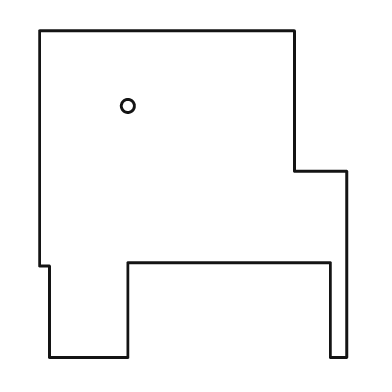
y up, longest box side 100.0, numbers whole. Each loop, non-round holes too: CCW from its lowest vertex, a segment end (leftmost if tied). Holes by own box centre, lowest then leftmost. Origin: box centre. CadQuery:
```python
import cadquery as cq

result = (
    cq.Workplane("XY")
    .moveTo(-44.0, -50.0)
    .lineTo(-20.0, -50.0)
    .lineTo(-20.0, -21.0)
    .lineTo(42.0, -21.0)
    .lineTo(42.0, -50.0)
    .lineTo(47.0, -50.0)
    .lineTo(47.0, 7.0)
    .lineTo(31.0, 7.0)
    .lineTo(31.0, 50.0)
    .lineTo(-47.0, 50.0)
    .lineTo(-47.0, -22.0)
    .lineTo(-44.0, -22.0)
    .close()
    .moveTo(-20.0, 27.0)
    .circle(2.0)
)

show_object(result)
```